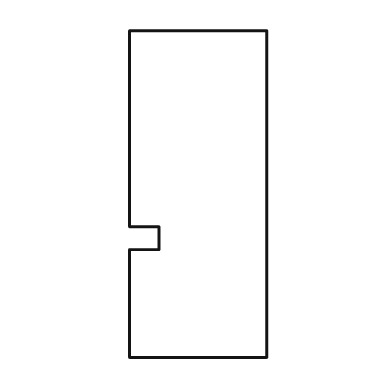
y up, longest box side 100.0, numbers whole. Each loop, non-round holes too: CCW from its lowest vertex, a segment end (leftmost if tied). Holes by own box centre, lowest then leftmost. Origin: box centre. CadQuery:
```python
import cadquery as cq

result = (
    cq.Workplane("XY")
    .moveTo(-21.0, -50.0)
    .lineTo(21.0, -50.0)
    .lineTo(21.0, 50.0)
    .lineTo(-21.0, 50.0)
    .lineTo(-21.0, -10.0)
    .lineTo(-12.0, -10.0)
    .lineTo(-12.0, -17.0)
    .lineTo(-21.0, -17.0)
    .close()
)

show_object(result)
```